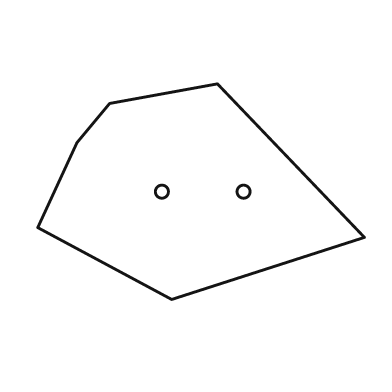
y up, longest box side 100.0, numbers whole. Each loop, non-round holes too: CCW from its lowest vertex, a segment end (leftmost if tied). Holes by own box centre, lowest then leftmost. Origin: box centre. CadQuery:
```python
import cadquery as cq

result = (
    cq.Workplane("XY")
    .moveTo(-9.0, -33.0)
    .lineTo(50.0, -14.0)
    .lineTo(5.0, 33.0)
    .lineTo(-28.0, 27.0)
    .lineTo(-38.0, 15.0)
    .lineTo(-50.0, -11.0)
    .close()
    .moveTo(-12.0, 0.0)
    .circle(2.0)
    .moveTo(13.0, 0.0)
    .circle(2.0)
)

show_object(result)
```